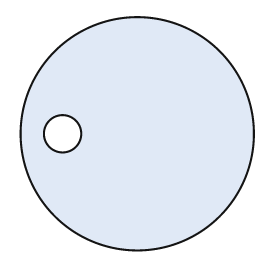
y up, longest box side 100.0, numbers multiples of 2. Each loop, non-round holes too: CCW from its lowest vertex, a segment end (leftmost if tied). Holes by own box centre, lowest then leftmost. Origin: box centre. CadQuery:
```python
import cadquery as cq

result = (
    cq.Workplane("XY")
    .moveTo(0.0, 0.0)
    .circle(50.0)
    .moveTo(-32.0, 0.0)
    .circle(8.0)
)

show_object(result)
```